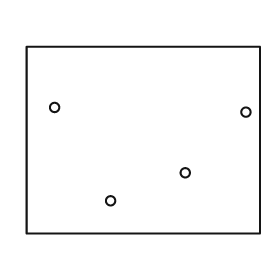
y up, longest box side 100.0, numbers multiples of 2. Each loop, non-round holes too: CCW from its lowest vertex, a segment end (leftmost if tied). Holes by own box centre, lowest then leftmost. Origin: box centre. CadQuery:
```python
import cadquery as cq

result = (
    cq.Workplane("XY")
    .moveTo(-50.0, -40.0)
    .lineTo(50.0, -40.0)
    .lineTo(50.0, 40.0)
    .lineTo(-50.0, 40.0)
    .close()
    .moveTo(-14.0, -26.0)
    .circle(2.0)
    .moveTo(18.0, -14.0)
    .circle(2.0)
    .moveTo(44.0, 12.0)
    .circle(2.0)
    .moveTo(-38.0, 14.0)
    .circle(2.0)
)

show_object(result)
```